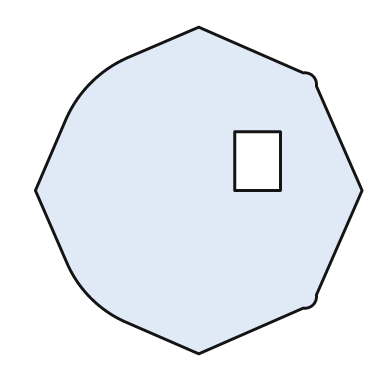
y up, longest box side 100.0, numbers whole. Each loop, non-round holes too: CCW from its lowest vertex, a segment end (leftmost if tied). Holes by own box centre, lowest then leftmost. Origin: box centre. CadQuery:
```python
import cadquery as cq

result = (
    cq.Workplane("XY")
    .moveTo(0.0, -50.0)
    .lineTo(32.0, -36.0)
    .threePointArc((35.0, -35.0), (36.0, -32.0))
    .lineTo(50.0, 0.0)
    .lineTo(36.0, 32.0)
    .threePointArc((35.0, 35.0), (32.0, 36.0))
    .lineTo(0.0, 50.0)
    .lineTo(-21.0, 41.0)
    .threePointArc((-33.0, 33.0), (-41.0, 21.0))
    .lineTo(-50.0, 0.0)
    .lineTo(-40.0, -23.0)
    .threePointArc((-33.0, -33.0), (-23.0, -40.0))
    .close()
    .moveTo(11.0, 0.0)
    .lineTo(25.0, 0.0)
    .lineTo(25.0, 18.0)
    .lineTo(11.0, 18.0)
    .close()
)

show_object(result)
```